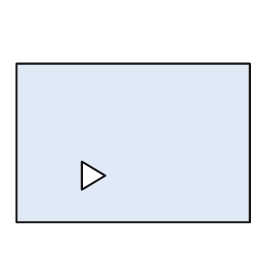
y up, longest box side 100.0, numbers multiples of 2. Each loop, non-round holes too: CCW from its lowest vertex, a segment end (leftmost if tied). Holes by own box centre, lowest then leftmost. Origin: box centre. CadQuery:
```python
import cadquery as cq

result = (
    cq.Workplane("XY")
    .moveTo(-50.0, -34.0)
    .lineTo(50.0, -34.0)
    .lineTo(50.0, 34.0)
    .lineTo(-50.0, 34.0)
    .close()
    .moveTo(-22.0, -20.0)
    .lineTo(-12.0, -14.0)
    .lineTo(-22.0, -8.0)
    .close()
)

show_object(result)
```